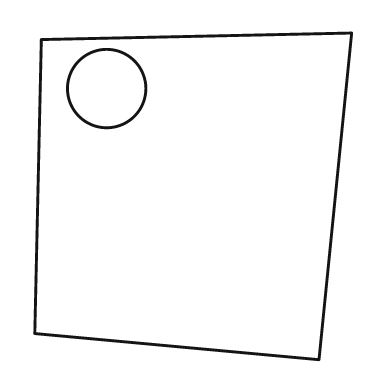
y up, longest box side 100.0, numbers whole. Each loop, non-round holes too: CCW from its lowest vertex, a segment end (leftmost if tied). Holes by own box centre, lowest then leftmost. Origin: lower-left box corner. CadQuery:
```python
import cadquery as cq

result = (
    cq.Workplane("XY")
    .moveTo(87.0, 0.0)
    .lineTo(97.0, 100.0)
    .lineTo(2.0, 98.0)
    .lineTo(0.0, 8.0)
    .close()
    .moveTo(22.0, 83.0)
    .circle(12.0)
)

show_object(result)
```